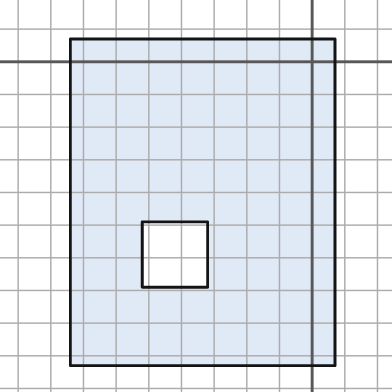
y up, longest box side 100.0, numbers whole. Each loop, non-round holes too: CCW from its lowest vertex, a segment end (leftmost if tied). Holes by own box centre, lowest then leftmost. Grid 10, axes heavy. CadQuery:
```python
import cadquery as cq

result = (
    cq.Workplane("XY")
    .moveTo(-74.0, -93.0)
    .lineTo(7.0, -93.0)
    .lineTo(7.0, 7.0)
    .lineTo(-74.0, 7.0)
    .close()
    .moveTo(-52.0, -69.0)
    .lineTo(-32.0, -69.0)
    .lineTo(-32.0, -49.0)
    .lineTo(-52.0, -49.0)
    .close()
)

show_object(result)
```